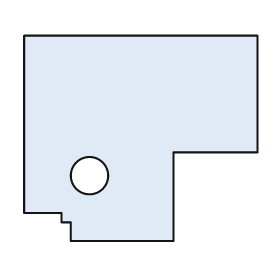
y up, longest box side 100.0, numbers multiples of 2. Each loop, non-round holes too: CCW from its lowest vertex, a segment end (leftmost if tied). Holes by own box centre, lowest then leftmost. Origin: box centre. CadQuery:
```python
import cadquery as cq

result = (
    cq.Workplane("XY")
    .moveTo(-30.0, -44.0)
    .lineTo(14.0, -44.0)
    .lineTo(14.0, -6.0)
    .lineTo(50.0, -6.0)
    .lineTo(50.0, 44.0)
    .lineTo(-50.0, 44.0)
    .lineTo(-50.0, -32.0)
    .lineTo(-34.0, -32.0)
    .lineTo(-34.0, -36.0)
    .lineTo(-30.0, -36.0)
    .close()
    .moveTo(-22.0, -16.0)
    .circle(8.0)
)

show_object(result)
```